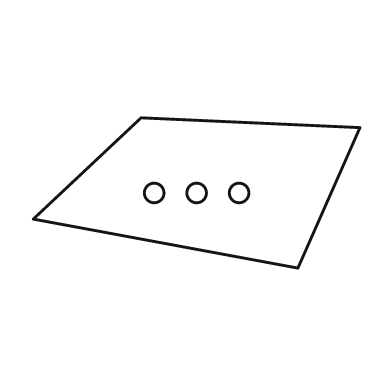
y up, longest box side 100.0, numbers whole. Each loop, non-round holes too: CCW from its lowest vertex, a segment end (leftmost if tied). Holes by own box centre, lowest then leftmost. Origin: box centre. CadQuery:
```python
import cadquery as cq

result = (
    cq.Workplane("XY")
    .moveTo(31.0, -23.0)
    .lineTo(50.0, 20.0)
    .lineTo(-17.0, 23.0)
    .lineTo(-50.0, -8.0)
    .close()
    .moveTo(-13.0, 0.0)
    .circle(3.0)
    .moveTo(0.0, 0.0)
    .circle(3.0)
    .moveTo(13.0, 0.0)
    .circle(3.0)
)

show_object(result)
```